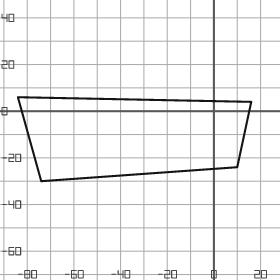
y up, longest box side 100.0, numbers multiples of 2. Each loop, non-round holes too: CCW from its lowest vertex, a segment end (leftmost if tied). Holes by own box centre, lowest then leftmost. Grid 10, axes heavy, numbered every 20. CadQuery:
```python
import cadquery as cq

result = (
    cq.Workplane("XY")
    .moveTo(-74.0, -30.0)
    .lineTo(10.0, -24.0)
    .lineTo(16.0, 4.0)
    .lineTo(-84.0, 6.0)
    .close()
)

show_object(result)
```